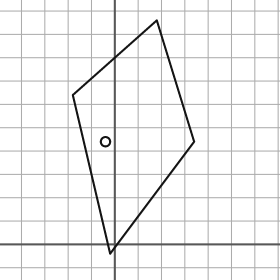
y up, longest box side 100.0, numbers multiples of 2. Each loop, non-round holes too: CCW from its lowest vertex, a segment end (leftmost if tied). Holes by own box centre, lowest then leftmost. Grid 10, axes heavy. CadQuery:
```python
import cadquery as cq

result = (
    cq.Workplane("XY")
    .moveTo(-2.0, -4.0)
    .lineTo(34.0, 44.0)
    .lineTo(18.0, 96.0)
    .lineTo(-18.0, 64.0)
    .close()
    .moveTo(-4.0, 44.0)
    .circle(2.0)
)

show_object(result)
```